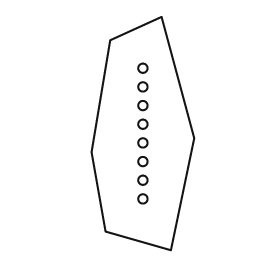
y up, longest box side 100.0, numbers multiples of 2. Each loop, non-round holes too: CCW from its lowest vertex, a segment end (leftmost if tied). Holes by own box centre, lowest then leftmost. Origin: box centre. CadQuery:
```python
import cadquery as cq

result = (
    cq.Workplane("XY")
    .moveTo(12.0, -50.0)
    .lineTo(22.0, -2.0)
    .lineTo(8.0, 50.0)
    .lineTo(-14.0, 40.0)
    .lineTo(-22.0, -8.0)
    .lineTo(-16.0, -42.0)
    .close()
    .moveTo(0.0, -28.0)
    .circle(2.0)
    .moveTo(0.0, -20.0)
    .circle(2.0)
    .moveTo(0.0, -12.0)
    .circle(2.0)
    .moveTo(0.0, -4.0)
    .circle(2.0)
    .moveTo(0.0, 4.0)
    .circle(2.0)
    .moveTo(0.0, 12.0)
    .circle(2.0)
    .moveTo(0.0, 20.0)
    .circle(2.0)
    .moveTo(0.0, 28.0)
    .circle(2.0)
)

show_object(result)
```